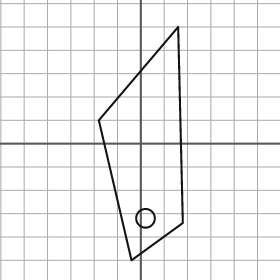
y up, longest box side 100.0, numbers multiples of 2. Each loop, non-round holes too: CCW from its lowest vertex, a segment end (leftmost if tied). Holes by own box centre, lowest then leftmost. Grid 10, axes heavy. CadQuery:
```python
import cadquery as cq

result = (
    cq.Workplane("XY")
    .moveTo(-4.0, -50.0)
    .lineTo(18.0, -34.0)
    .lineTo(16.0, 50.0)
    .lineTo(-18.0, 10.0)
    .close()
    .moveTo(2.0, -32.0)
    .circle(4.0)
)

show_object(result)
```